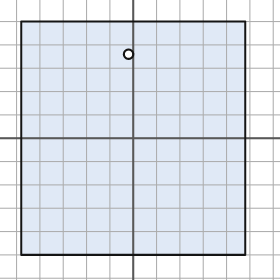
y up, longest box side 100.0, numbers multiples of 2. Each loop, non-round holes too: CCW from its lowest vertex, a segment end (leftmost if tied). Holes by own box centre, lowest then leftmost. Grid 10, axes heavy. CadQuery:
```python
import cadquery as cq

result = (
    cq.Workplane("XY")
    .moveTo(-48.0, -50.0)
    .lineTo(48.0, -50.0)
    .lineTo(48.0, 50.0)
    .lineTo(-48.0, 50.0)
    .close()
    .moveTo(-2.0, 36.0)
    .circle(2.0)
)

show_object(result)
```